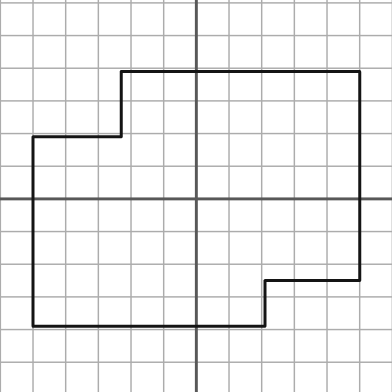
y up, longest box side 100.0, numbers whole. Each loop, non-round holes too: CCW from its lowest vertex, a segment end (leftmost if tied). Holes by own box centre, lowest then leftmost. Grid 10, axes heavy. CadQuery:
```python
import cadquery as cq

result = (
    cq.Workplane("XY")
    .moveTo(-50.0, -39.0)
    .lineTo(21.0, -39.0)
    .lineTo(21.0, -25.0)
    .lineTo(50.0, -25.0)
    .lineTo(50.0, 39.0)
    .lineTo(-23.0, 39.0)
    .lineTo(-23.0, 19.0)
    .lineTo(-50.0, 19.0)
    .close()
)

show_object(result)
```